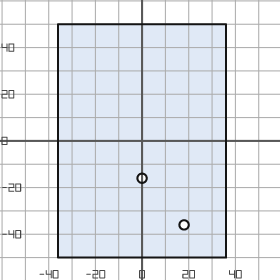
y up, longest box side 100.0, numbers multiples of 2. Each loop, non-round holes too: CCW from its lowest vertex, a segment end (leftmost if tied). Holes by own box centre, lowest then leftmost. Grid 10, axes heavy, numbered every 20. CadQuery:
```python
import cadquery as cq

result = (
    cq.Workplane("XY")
    .moveTo(-36.0, -50.0)
    .lineTo(36.0, -50.0)
    .lineTo(36.0, 50.0)
    .lineTo(-36.0, 50.0)
    .close()
    .moveTo(18.0, -36.0)
    .circle(2.0)
    .moveTo(0.0, -16.0)
    .circle(2.0)
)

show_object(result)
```